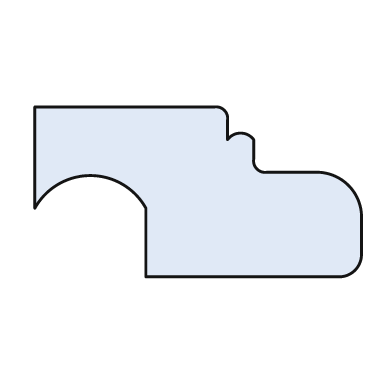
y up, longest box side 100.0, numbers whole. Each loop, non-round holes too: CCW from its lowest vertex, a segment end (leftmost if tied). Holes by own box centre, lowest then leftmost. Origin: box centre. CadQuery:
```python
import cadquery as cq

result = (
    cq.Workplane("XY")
    .moveTo(-16.0, -26.0)
    .lineTo(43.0, -26.0)
    .threePointArc((48.0, -24.0), (50.0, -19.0))
    .lineTo(50.0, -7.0)
    .threePointArc((46.0, 2.0), (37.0, 6.0))
    .lineTo(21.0, 6.0)
    .threePointArc((18.0, 7.0), (17.0, 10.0))
    .lineTo(17.0, 16.0)
    .threePointArc((13.0, 18.0), (9.0, 16.0))
    .lineTo(9.0, 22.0)
    .threePointArc((8.0, 25.0), (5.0, 26.0))
    .lineTo(-50.0, 26.0)
    .lineTo(-50.0, -5.0)
    .threePointArc((-33.0, 5.0), (-16.0, -5.0))
    .close()
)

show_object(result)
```